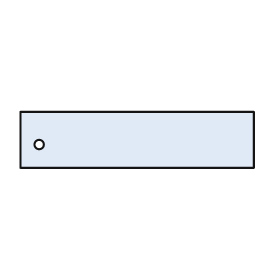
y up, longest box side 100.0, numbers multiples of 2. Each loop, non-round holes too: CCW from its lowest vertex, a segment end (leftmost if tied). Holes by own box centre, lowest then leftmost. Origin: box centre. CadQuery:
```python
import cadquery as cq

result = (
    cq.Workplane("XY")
    .moveTo(-50.0, -12.0)
    .lineTo(50.0, -12.0)
    .lineTo(50.0, 12.0)
    .lineTo(-50.0, 12.0)
    .close()
    .moveTo(-42.0, -2.0)
    .circle(2.0)
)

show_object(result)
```